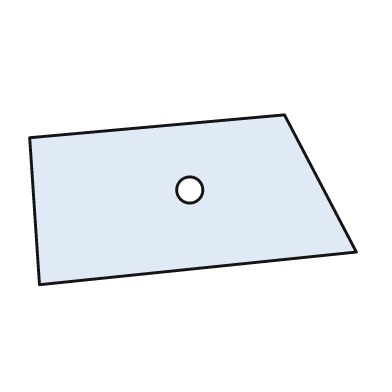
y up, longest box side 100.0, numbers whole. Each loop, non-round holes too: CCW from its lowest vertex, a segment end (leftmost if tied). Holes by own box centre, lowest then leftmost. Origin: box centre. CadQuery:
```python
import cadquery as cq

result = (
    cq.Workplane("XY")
    .moveTo(-47.0, -26.0)
    .lineTo(50.0, -16.0)
    .lineTo(28.0, 26.0)
    .lineTo(-50.0, 19.0)
    .close()
    .moveTo(-1.0, 3.0)
    .circle(4.0)
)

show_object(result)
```